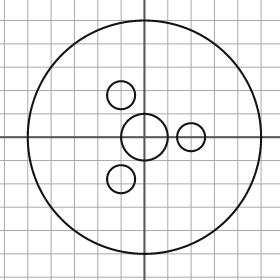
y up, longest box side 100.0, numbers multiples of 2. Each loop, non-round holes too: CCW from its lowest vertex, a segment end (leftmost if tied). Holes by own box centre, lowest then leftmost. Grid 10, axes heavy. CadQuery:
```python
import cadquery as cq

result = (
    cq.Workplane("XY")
    .moveTo(0.0, 0.0)
    .circle(50.0)
    .moveTo(-10.0, -18.0)
    .circle(6.0)
    .moveTo(0.0, 0.0)
    .circle(10.0)
    .moveTo(20.0, 0.0)
    .circle(6.0)
    .moveTo(-10.0, 18.0)
    .circle(6.0)
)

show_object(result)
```